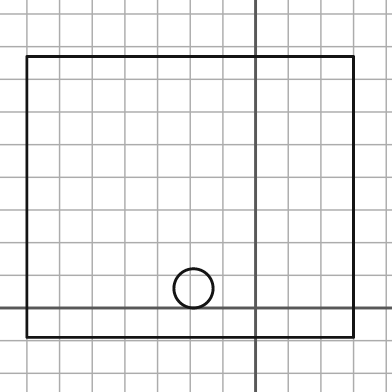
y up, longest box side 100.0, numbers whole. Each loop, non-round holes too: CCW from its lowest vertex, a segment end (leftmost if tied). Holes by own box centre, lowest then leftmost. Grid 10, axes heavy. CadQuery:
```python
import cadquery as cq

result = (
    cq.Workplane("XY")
    .moveTo(-70.0, -9.0)
    .lineTo(30.0, -9.0)
    .lineTo(30.0, 77.0)
    .lineTo(-70.0, 77.0)
    .close()
    .moveTo(-19.0, 6.0)
    .circle(6.0)
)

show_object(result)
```